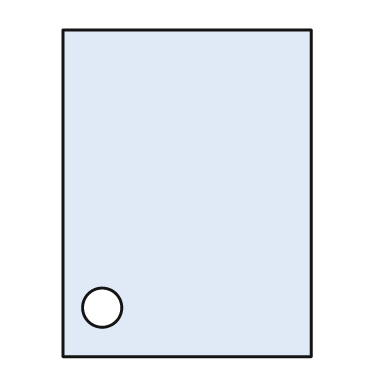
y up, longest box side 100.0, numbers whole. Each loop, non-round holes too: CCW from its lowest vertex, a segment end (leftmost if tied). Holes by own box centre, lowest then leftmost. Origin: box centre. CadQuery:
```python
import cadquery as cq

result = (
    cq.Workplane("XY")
    .moveTo(-38.0, -50.0)
    .lineTo(38.0, -50.0)
    .lineTo(38.0, 50.0)
    .lineTo(-38.0, 50.0)
    .close()
    .moveTo(-26.0, -35.0)
    .circle(6.0)
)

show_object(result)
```